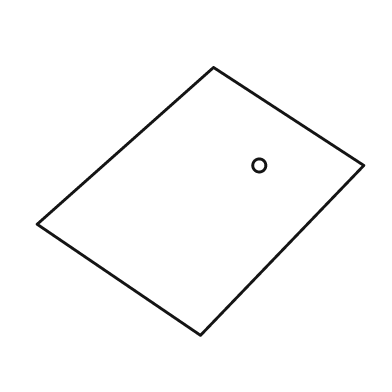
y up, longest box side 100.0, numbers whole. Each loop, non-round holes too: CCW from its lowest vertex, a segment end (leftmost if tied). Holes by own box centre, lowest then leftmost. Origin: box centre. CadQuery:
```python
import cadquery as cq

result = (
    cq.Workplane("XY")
    .moveTo(0.0, -41.0)
    .lineTo(50.0, 11.0)
    .lineTo(4.0, 41.0)
    .lineTo(-50.0, -7.0)
    .close()
    .moveTo(18.0, 11.0)
    .circle(2.0)
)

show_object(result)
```